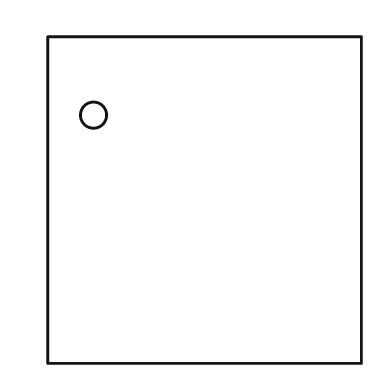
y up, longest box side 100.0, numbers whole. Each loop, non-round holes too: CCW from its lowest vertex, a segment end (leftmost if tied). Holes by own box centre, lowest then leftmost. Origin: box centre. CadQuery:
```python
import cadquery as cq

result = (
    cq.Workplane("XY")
    .moveTo(-48.0, -50.0)
    .lineTo(48.0, -50.0)
    .lineTo(48.0, 50.0)
    .lineTo(-48.0, 50.0)
    .close()
    .moveTo(-34.0, 26.0)
    .circle(4.0)
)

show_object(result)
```